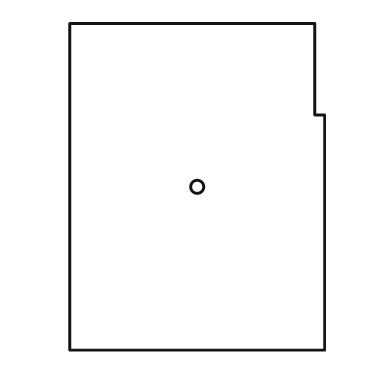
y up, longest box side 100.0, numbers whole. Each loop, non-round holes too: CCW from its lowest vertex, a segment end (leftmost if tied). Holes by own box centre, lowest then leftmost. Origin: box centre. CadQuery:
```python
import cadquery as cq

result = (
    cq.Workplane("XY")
    .moveTo(-39.0, -50.0)
    .lineTo(39.0, -50.0)
    .lineTo(39.0, 22.0)
    .lineTo(36.0, 22.0)
    .lineTo(36.0, 50.0)
    .lineTo(-39.0, 50.0)
    .close()
    .moveTo(0.0, 0.0)
    .circle(2.0)
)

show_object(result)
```